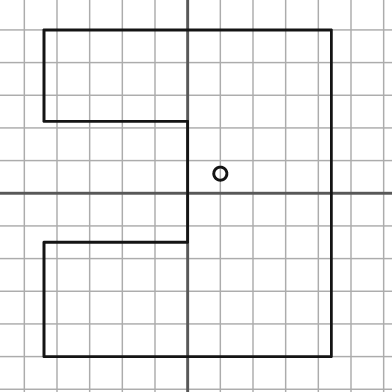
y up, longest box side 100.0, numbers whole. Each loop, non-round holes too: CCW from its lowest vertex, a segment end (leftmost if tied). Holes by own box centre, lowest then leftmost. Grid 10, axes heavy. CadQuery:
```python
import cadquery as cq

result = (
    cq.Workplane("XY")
    .moveTo(-44.0, -50.0)
    .lineTo(44.0, -50.0)
    .lineTo(44.0, 50.0)
    .lineTo(-44.0, 50.0)
    .lineTo(-44.0, 22.0)
    .lineTo(0.0, 22.0)
    .lineTo(0.0, -15.0)
    .lineTo(-44.0, -15.0)
    .close()
    .moveTo(10.0, 6.0)
    .circle(2.0)
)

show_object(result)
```